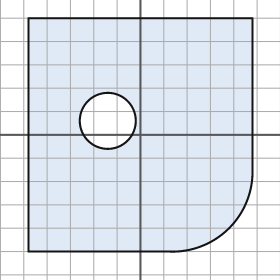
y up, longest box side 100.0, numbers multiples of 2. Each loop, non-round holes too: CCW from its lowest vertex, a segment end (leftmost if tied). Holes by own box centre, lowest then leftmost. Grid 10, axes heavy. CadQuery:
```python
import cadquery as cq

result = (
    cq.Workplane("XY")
    .moveTo(-48.0, -50.0)
    .lineTo(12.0, -50.0)
    .threePointArc((38.0, -40.0), (48.0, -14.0))
    .lineTo(48.0, 50.0)
    .lineTo(-48.0, 50.0)
    .close()
    .moveTo(-14.0, 6.0)
    .circle(12.0)
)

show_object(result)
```